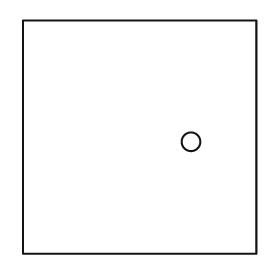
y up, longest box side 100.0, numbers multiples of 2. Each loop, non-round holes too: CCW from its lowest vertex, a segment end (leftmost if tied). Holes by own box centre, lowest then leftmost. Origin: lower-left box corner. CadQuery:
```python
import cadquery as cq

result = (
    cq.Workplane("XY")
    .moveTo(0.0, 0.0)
    .lineTo(100.0, 0.0)
    .lineTo(100.0, 100.0)
    .lineTo(0.0, 100.0)
    .close()
    .moveTo(72.0, 48.0)
    .circle(4.0)
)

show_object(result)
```